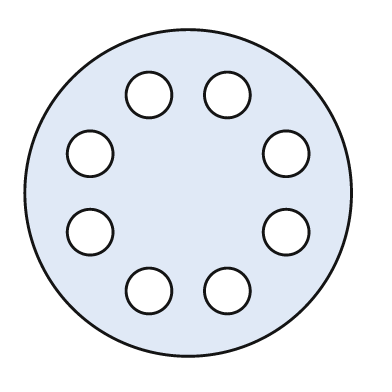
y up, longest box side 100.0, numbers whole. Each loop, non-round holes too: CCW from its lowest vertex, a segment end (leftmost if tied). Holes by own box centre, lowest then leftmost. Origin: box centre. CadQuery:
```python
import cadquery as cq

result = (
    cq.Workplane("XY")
    .moveTo(0.0, 0.0)
    .circle(50.0)
    .moveTo(-12.0, -30.0)
    .circle(7.0)
    .moveTo(12.0, -30.0)
    .circle(7.0)
    .moveTo(-30.0, -12.0)
    .circle(7.0)
    .moveTo(30.0, -12.0)
    .circle(7.0)
    .moveTo(-30.0, 12.0)
    .circle(7.0)
    .moveTo(30.0, 12.0)
    .circle(7.0)
    .moveTo(-12.0, 30.0)
    .circle(7.0)
    .moveTo(12.0, 30.0)
    .circle(7.0)
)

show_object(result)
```